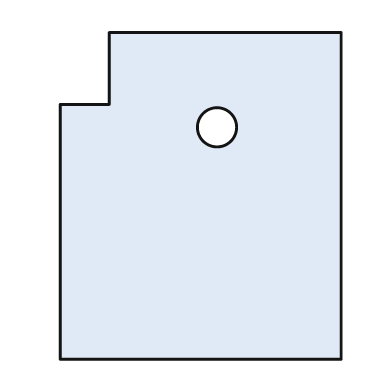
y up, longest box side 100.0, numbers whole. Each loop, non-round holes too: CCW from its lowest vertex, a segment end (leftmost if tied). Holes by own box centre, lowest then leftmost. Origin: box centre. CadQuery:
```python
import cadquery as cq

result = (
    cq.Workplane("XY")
    .moveTo(-43.0, -50.0)
    .lineTo(43.0, -50.0)
    .lineTo(43.0, 50.0)
    .lineTo(-28.0, 50.0)
    .lineTo(-28.0, 28.0)
    .lineTo(-43.0, 28.0)
    .close()
    .moveTo(5.0, 21.0)
    .circle(6.0)
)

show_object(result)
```